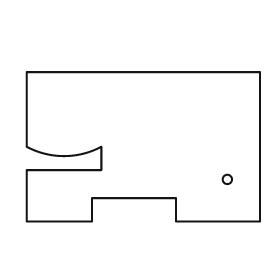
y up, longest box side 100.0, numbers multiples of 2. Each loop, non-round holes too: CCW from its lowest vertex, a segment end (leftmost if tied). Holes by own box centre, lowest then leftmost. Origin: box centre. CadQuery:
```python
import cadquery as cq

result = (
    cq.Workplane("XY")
    .moveTo(-50.0, -32.0)
    .lineTo(-22.0, -32.0)
    .lineTo(-22.0, -22.0)
    .lineTo(14.0, -22.0)
    .lineTo(14.0, -32.0)
    .lineTo(50.0, -32.0)
    .lineTo(50.0, 32.0)
    .lineTo(-50.0, 32.0)
    .lineTo(-50.0, 0.0)
    .threePointArc((-34.0, -4.0), (-18.0, 0.0))
    .lineTo(-18.0, -10.0)
    .lineTo(-50.0, -10.0)
    .close()
    .moveTo(36.0, -14.0)
    .circle(2.0)
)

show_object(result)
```